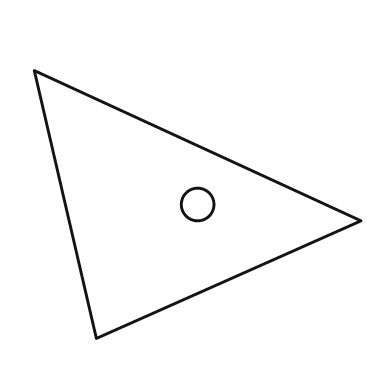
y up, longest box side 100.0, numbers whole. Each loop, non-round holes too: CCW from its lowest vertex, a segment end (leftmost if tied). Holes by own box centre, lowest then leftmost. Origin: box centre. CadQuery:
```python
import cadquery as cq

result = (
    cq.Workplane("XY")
    .moveTo(-31.0, -41.0)
    .lineTo(50.0, -5.0)
    .lineTo(-50.0, 41.0)
    .close()
    .moveTo(0.0, 0.0)
    .circle(5.0)
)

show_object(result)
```